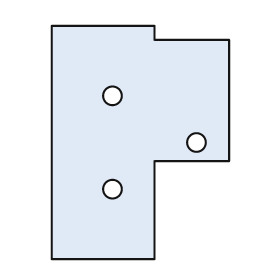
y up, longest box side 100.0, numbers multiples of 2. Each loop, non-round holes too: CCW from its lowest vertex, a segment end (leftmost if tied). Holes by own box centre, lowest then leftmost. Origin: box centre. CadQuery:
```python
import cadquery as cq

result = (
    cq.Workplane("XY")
    .moveTo(-38.0, -50.0)
    .lineTo(6.0, -50.0)
    .lineTo(6.0, -8.0)
    .lineTo(38.0, -8.0)
    .lineTo(38.0, 44.0)
    .lineTo(6.0, 44.0)
    .lineTo(6.0, 50.0)
    .lineTo(-38.0, 50.0)
    .close()
    .moveTo(-12.0, -20.0)
    .circle(4.0)
    .moveTo(24.0, 0.0)
    .circle(4.0)
    .moveTo(-12.0, 20.0)
    .circle(4.0)
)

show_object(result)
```